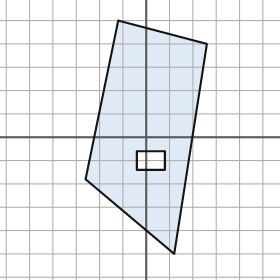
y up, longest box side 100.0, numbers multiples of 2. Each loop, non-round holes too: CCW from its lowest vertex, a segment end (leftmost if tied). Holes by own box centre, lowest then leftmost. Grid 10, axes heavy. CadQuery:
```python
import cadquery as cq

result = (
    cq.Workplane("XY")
    .moveTo(12.0, -50.0)
    .lineTo(26.0, 40.0)
    .lineTo(-12.0, 50.0)
    .lineTo(-26.0, -18.0)
    .close()
    .moveTo(-4.0, -14.0)
    .lineTo(8.0, -14.0)
    .lineTo(8.0, -6.0)
    .lineTo(-4.0, -6.0)
    .close()
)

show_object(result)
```